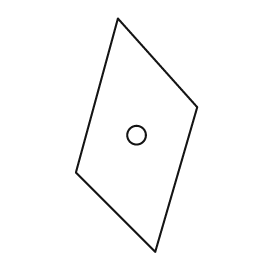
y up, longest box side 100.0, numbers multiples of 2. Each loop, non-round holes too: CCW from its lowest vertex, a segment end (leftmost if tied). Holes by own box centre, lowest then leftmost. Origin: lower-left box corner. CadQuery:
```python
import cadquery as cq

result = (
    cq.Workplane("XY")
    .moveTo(34.0, 0.0)
    .lineTo(52.0, 62.0)
    .lineTo(18.0, 100.0)
    .lineTo(0.0, 34.0)
    .close()
    .moveTo(26.0, 50.0)
    .circle(4.0)
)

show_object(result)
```